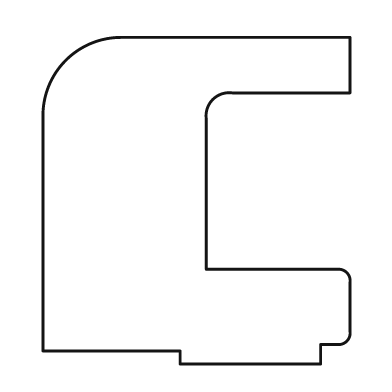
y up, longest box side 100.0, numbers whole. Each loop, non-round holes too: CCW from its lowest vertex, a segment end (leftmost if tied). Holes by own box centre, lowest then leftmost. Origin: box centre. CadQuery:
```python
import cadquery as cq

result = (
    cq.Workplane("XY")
    .moveTo(-5.0, -50.0)
    .lineTo(38.0, -50.0)
    .lineTo(38.0, -44.0)
    .lineTo(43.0, -44.0)
    .threePointArc((46.0, -43.0), (47.0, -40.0))
    .lineTo(47.0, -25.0)
    .threePointArc((46.0, -22.0), (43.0, -21.0))
    .lineTo(3.0, -21.0)
    .lineTo(3.0, 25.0)
    .threePointArc((5.0, 31.0), (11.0, 33.0))
    .lineTo(47.0, 33.0)
    .lineTo(47.0, 50.0)
    .lineTo(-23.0, 50.0)
    .threePointArc((-40.0, 43.0), (-47.0, 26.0))
    .lineTo(-47.0, -46.0)
    .lineTo(-5.0, -46.0)
    .close()
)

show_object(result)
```